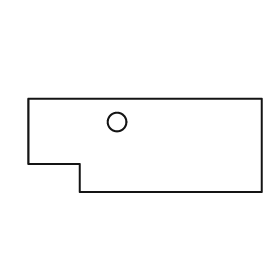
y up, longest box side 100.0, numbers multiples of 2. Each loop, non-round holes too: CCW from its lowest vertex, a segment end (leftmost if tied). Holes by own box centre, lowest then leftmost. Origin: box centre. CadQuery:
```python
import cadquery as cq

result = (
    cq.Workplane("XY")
    .moveTo(-28.0, -20.0)
    .lineTo(50.0, -20.0)
    .lineTo(50.0, 20.0)
    .lineTo(-50.0, 20.0)
    .lineTo(-50.0, -8.0)
    .lineTo(-28.0, -8.0)
    .close()
    .moveTo(-12.0, 10.0)
    .circle(4.0)
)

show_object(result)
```